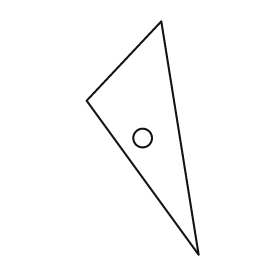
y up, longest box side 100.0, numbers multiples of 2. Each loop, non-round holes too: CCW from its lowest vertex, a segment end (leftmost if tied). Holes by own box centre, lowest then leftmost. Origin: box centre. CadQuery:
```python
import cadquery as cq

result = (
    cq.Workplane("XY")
    .moveTo(24.0, -50.0)
    .lineTo(8.0, 50.0)
    .lineTo(-24.0, 16.0)
    .close()
    .moveTo(0.0, 0.0)
    .circle(4.0)
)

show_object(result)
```